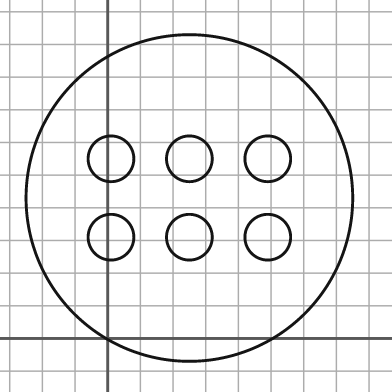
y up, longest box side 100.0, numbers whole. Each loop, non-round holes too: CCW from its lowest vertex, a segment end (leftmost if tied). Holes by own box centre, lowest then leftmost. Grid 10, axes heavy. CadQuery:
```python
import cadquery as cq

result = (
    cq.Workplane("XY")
    .moveTo(25.0, 43.0)
    .circle(50.0)
    .moveTo(1.0, 31.0)
    .circle(7.0)
    .moveTo(25.0, 31.0)
    .circle(7.0)
    .moveTo(49.0, 31.0)
    .circle(7.0)
    .moveTo(1.0, 55.0)
    .circle(7.0)
    .moveTo(25.0, 55.0)
    .circle(7.0)
    .moveTo(49.0, 55.0)
    .circle(7.0)
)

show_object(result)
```